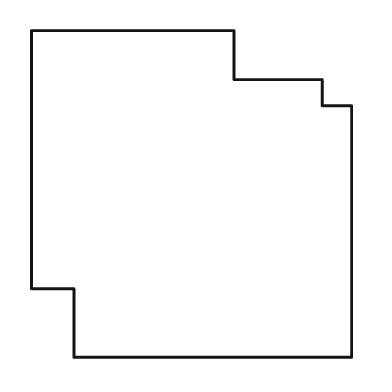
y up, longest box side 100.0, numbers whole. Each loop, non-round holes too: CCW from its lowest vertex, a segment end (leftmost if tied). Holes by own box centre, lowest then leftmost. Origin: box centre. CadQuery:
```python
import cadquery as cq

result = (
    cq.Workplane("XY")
    .moveTo(-36.0, -50.0)
    .lineTo(49.0, -50.0)
    .lineTo(49.0, 27.0)
    .lineTo(40.0, 27.0)
    .lineTo(40.0, 35.0)
    .lineTo(13.0, 35.0)
    .lineTo(13.0, 50.0)
    .lineTo(-49.0, 50.0)
    .lineTo(-49.0, -29.0)
    .lineTo(-36.0, -29.0)
    .close()
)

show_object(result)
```